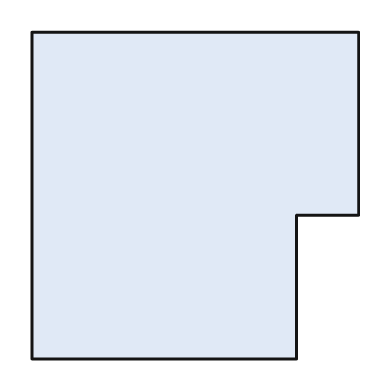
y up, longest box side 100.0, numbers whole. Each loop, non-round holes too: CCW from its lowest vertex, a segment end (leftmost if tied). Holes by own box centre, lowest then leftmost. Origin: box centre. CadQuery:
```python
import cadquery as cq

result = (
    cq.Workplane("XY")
    .moveTo(-50.0, -50.0)
    .lineTo(31.0, -50.0)
    .lineTo(31.0, -6.0)
    .lineTo(50.0, -6.0)
    .lineTo(50.0, 50.0)
    .lineTo(-50.0, 50.0)
    .close()
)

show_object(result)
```